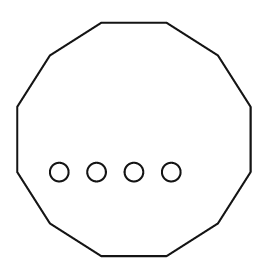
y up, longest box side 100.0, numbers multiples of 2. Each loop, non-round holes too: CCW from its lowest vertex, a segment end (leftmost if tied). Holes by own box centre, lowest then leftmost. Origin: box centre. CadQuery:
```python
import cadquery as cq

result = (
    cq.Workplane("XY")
    .moveTo(-14.0, -50.0)
    .lineTo(14.0, -50.0)
    .lineTo(36.0, -36.0)
    .lineTo(50.0, -14.0)
    .lineTo(50.0, 14.0)
    .lineTo(36.0, 36.0)
    .lineTo(14.0, 50.0)
    .lineTo(-14.0, 50.0)
    .lineTo(-36.0, 36.0)
    .lineTo(-50.0, 14.0)
    .lineTo(-50.0, -14.0)
    .lineTo(-36.0, -36.0)
    .close()
    .moveTo(-32.0, -14.0)
    .circle(4.0)
    .moveTo(-16.0, -14.0)
    .circle(4.0)
    .moveTo(0.0, -14.0)
    .circle(4.0)
    .moveTo(16.0, -14.0)
    .circle(4.0)
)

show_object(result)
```